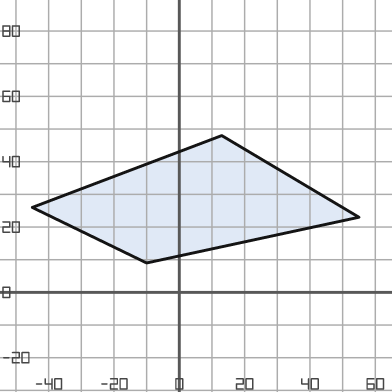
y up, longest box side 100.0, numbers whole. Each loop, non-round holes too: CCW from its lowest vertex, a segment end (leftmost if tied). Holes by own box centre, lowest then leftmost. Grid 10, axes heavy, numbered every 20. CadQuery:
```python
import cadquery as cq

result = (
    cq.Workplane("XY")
    .moveTo(-10.0, 9.0)
    .lineTo(55.0, 23.0)
    .lineTo(13.0, 48.0)
    .lineTo(-45.0, 26.0)
    .close()
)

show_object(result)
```